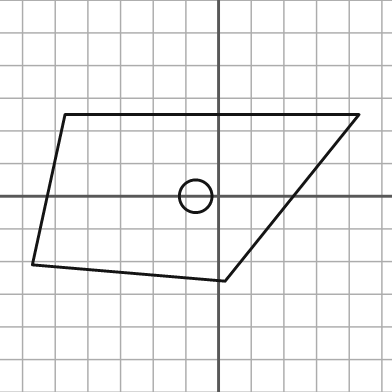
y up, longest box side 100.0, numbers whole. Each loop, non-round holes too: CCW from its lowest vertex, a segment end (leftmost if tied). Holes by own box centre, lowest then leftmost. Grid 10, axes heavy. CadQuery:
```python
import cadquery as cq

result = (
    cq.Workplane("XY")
    .moveTo(2.0, -26.0)
    .lineTo(43.0, 25.0)
    .lineTo(-47.0, 25.0)
    .lineTo(-57.0, -21.0)
    .close()
    .moveTo(-7.0, 0.0)
    .circle(5.0)
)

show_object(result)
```